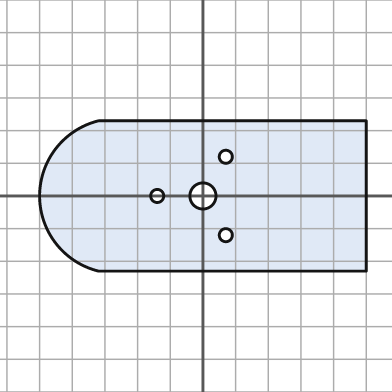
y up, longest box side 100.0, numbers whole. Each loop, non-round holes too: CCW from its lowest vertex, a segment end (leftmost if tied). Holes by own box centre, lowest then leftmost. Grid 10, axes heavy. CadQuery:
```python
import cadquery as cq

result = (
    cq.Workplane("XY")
    .moveTo(-32.0, -23.0)
    .lineTo(50.0, -23.0)
    .lineTo(50.0, 23.0)
    .lineTo(-32.0, 23.0)
    .threePointArc((-50.0, 0.0), (-32.0, -23.0))
    .close()
    .moveTo(7.0, -12.0)
    .circle(2.0)
    .moveTo(-14.0, 0.0)
    .circle(2.0)
    .moveTo(0.0, 0.0)
    .circle(4.0)
    .moveTo(7.0, 12.0)
    .circle(2.0)
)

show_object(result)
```